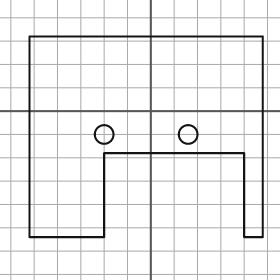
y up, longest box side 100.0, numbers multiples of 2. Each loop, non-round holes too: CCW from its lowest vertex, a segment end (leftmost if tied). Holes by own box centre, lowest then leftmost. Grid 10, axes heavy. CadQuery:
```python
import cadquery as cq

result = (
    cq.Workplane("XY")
    .moveTo(-52.0, -54.0)
    .lineTo(-20.0, -54.0)
    .lineTo(-20.0, -18.0)
    .lineTo(40.0, -18.0)
    .lineTo(40.0, -54.0)
    .lineTo(48.0, -54.0)
    .lineTo(48.0, 32.0)
    .lineTo(-52.0, 32.0)
    .close()
    .moveTo(-20.0, -10.0)
    .circle(4.0)
    .moveTo(16.0, -10.0)
    .circle(4.0)
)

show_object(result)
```